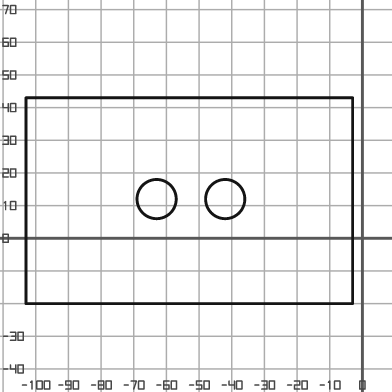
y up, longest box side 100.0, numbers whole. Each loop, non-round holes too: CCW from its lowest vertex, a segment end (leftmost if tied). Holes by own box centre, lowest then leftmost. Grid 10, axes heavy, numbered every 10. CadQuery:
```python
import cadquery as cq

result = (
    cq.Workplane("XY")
    .moveTo(-103.0, -20.0)
    .lineTo(-3.0, -20.0)
    .lineTo(-3.0, 43.0)
    .lineTo(-103.0, 43.0)
    .close()
    .moveTo(-63.0, 12.0)
    .circle(6.0)
    .moveTo(-42.0, 12.0)
    .circle(6.0)
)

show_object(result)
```